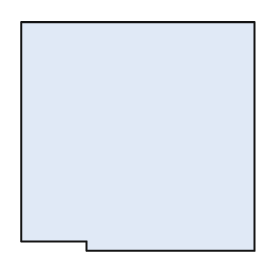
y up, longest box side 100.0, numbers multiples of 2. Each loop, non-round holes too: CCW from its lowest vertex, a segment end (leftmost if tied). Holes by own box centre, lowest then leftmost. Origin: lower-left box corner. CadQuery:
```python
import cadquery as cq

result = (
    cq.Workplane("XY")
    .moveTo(28.0, 0.0)
    .lineTo(100.0, 0.0)
    .lineTo(100.0, 98.0)
    .lineTo(0.0, 98.0)
    .lineTo(0.0, 4.0)
    .lineTo(28.0, 4.0)
    .close()
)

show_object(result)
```